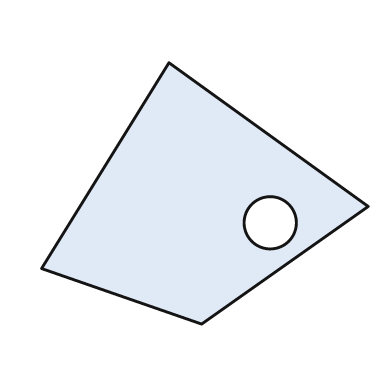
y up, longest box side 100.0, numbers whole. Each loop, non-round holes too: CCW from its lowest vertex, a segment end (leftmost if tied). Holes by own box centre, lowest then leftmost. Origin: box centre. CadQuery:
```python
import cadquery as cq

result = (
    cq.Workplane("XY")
    .moveTo(-1.0, -40.0)
    .lineTo(50.0, -4.0)
    .lineTo(-11.0, 40.0)
    .lineTo(-50.0, -23.0)
    .close()
    .moveTo(20.0, -9.0)
    .circle(8.0)
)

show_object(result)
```